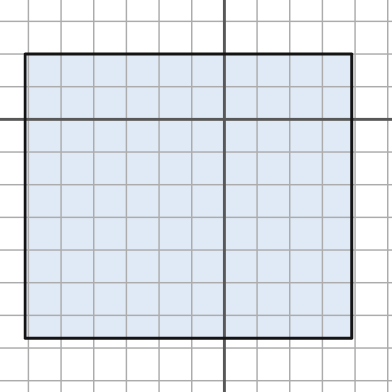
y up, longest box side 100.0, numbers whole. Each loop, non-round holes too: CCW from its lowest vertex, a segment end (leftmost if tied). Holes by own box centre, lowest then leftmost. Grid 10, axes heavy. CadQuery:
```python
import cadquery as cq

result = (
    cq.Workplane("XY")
    .moveTo(-61.0, -67.0)
    .lineTo(39.0, -67.0)
    .lineTo(39.0, 20.0)
    .lineTo(-61.0, 20.0)
    .close()
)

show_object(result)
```